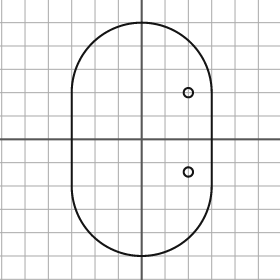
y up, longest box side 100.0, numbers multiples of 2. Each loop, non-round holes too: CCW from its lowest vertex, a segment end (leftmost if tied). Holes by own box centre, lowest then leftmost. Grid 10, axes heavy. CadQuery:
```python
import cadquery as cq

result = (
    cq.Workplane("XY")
    .moveTo(-30.0, -20.0)
    .threePointArc((0.0, -50.0), (30.0, -20.0))
    .lineTo(30.0, 20.0)
    .threePointArc((0.0, 50.0), (-30.0, 20.0))
    .close()
    .moveTo(20.0, -14.0)
    .circle(2.0)
    .moveTo(20.0, 20.0)
    .circle(2.0)
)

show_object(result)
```